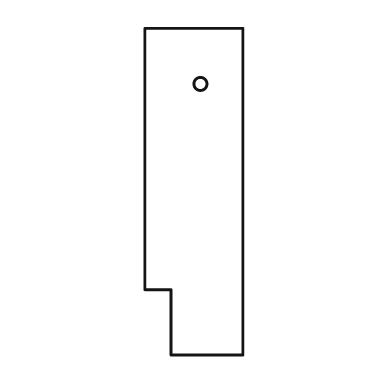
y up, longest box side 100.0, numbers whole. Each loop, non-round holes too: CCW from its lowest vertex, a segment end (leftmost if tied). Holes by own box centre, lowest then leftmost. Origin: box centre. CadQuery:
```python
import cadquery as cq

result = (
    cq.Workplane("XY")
    .moveTo(-7.0, -50.0)
    .lineTo(15.0, -50.0)
    .lineTo(15.0, 50.0)
    .lineTo(-15.0, 50.0)
    .lineTo(-15.0, -30.0)
    .lineTo(-7.0, -30.0)
    .close()
    .moveTo(2.0, 33.0)
    .circle(2.0)
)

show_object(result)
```